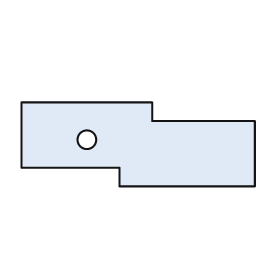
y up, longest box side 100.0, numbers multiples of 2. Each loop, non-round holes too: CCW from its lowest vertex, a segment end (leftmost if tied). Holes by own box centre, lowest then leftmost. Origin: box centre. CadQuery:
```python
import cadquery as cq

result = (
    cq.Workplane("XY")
    .moveTo(-8.0, -18.0)
    .lineTo(50.0, -18.0)
    .lineTo(50.0, 10.0)
    .lineTo(6.0, 10.0)
    .lineTo(6.0, 18.0)
    .lineTo(-50.0, 18.0)
    .lineTo(-50.0, -10.0)
    .lineTo(-8.0, -10.0)
    .close()
    .moveTo(-22.0, 2.0)
    .circle(4.0)
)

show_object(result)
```